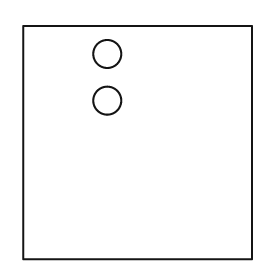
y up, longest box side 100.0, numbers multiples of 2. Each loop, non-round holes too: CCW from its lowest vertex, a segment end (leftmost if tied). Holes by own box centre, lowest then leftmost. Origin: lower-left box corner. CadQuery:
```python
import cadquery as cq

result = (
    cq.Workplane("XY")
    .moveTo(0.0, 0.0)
    .lineTo(98.0, 0.0)
    .lineTo(98.0, 100.0)
    .lineTo(0.0, 100.0)
    .close()
    .moveTo(36.0, 68.0)
    .circle(6.0)
    .moveTo(36.0, 88.0)
    .circle(6.0)
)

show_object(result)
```